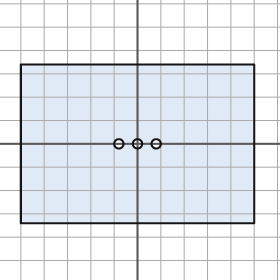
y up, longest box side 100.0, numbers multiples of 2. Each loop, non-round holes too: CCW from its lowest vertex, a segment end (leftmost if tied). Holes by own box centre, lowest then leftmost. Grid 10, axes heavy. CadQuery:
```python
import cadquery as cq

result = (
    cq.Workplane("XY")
    .moveTo(-50.0, -34.0)
    .lineTo(50.0, -34.0)
    .lineTo(50.0, 34.0)
    .lineTo(-50.0, 34.0)
    .close()
    .moveTo(-8.0, 0.0)
    .circle(2.0)
    .moveTo(0.0, 0.0)
    .circle(2.0)
    .moveTo(8.0, 0.0)
    .circle(2.0)
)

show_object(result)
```